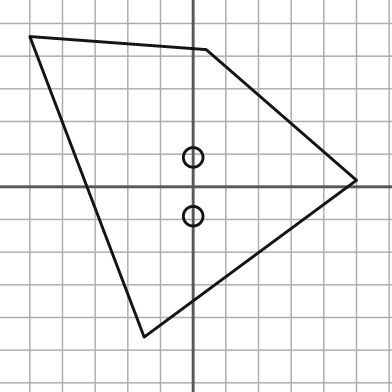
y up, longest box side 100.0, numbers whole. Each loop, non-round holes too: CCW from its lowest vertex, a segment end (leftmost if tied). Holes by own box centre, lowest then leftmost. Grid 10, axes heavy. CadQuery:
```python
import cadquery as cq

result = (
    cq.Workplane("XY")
    .moveTo(-15.0, -46.0)
    .lineTo(50.0, 2.0)
    .lineTo(4.0, 42.0)
    .lineTo(-50.0, 46.0)
    .close()
    .moveTo(0.0, -9.0)
    .circle(3.0)
    .moveTo(0.0, 9.0)
    .circle(3.0)
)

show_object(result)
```